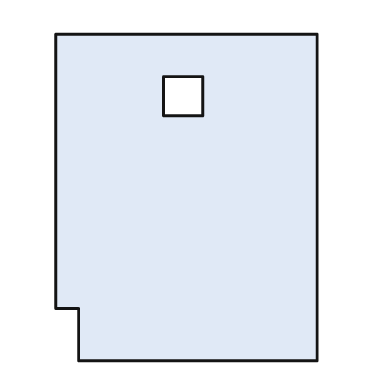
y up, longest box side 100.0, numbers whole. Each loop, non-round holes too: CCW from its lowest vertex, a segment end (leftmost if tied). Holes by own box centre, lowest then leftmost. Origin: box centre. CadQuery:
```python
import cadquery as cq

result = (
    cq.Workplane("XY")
    .moveTo(-33.0, -50.0)
    .lineTo(40.0, -50.0)
    .lineTo(40.0, 50.0)
    .lineTo(-40.0, 50.0)
    .lineTo(-40.0, -34.0)
    .lineTo(-33.0, -34.0)
    .close()
    .moveTo(-7.0, 25.0)
    .lineTo(5.0, 25.0)
    .lineTo(5.0, 37.0)
    .lineTo(-7.0, 37.0)
    .close()
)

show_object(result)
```